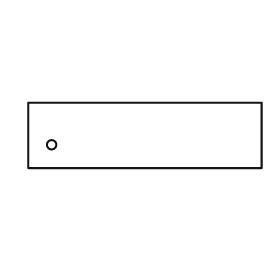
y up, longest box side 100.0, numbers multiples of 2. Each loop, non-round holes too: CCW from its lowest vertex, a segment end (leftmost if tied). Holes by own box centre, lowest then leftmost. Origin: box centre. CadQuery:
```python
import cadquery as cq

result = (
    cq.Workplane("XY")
    .moveTo(-50.0, -14.0)
    .lineTo(50.0, -14.0)
    .lineTo(50.0, 14.0)
    .lineTo(-50.0, 14.0)
    .close()
    .moveTo(-40.0, -4.0)
    .circle(2.0)
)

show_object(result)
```